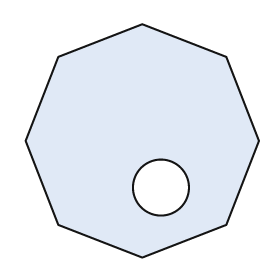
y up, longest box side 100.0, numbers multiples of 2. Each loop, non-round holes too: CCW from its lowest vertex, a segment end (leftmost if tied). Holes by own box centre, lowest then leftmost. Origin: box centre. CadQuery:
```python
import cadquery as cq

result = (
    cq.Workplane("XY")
    .moveTo(0.0, -50.0)
    .lineTo(36.0, -36.0)
    .lineTo(50.0, 0.0)
    .lineTo(36.0, 36.0)
    .lineTo(0.0, 50.0)
    .lineTo(-36.0, 36.0)
    .lineTo(-50.0, 0.0)
    .lineTo(-36.0, -36.0)
    .close()
    .moveTo(8.0, -20.0)
    .circle(12.0)
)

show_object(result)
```